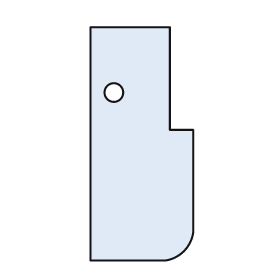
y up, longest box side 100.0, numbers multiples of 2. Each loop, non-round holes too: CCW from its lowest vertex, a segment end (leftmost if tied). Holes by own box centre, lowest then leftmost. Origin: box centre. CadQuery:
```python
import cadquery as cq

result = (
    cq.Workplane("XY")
    .moveTo(-22.0, -50.0)
    .lineTo(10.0, -50.0)
    .threePointArc((18.0, -46.0), (22.0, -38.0))
    .lineTo(22.0, 6.0)
    .lineTo(12.0, 6.0)
    .lineTo(12.0, 50.0)
    .lineTo(-22.0, 50.0)
    .close()
    .moveTo(-12.0, 22.0)
    .circle(4.0)
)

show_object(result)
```